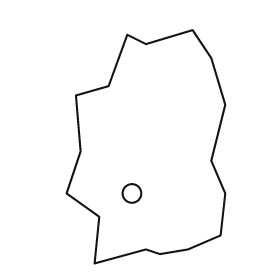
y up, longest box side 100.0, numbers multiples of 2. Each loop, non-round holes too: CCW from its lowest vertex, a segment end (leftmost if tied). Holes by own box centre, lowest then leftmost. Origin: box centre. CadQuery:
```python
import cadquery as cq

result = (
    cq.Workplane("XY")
    .moveTo(-22.0, -50.0)
    .lineTo(0.0, -44.0)
    .lineTo(6.0, -46.0)
    .lineTo(18.0, -44.0)
    .lineTo(32.0, -38.0)
    .lineTo(34.0, -20.0)
    .lineTo(28.0, -6.0)
    .lineTo(34.0, 18.0)
    .lineTo(28.0, 38.0)
    .lineTo(20.0, 50.0)
    .lineTo(0.0, 44.0)
    .lineTo(-8.0, 48.0)
    .lineTo(-16.0, 26.0)
    .lineTo(-30.0, 22.0)
    .lineTo(-28.0, -2.0)
    .lineTo(-34.0, -20.0)
    .lineTo(-20.0, -30.0)
    .close()
    .moveTo(-6.0, -20.0)
    .circle(4.0)
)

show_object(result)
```